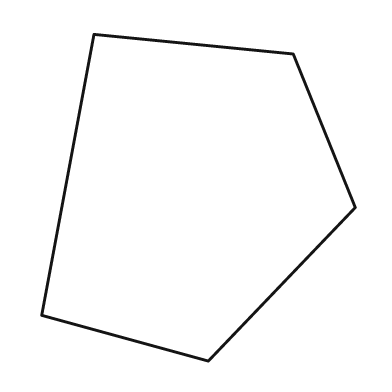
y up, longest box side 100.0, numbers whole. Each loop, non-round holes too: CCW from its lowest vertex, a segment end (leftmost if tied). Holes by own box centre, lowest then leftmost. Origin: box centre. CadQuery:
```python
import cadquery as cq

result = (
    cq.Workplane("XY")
    .moveTo(3.0, -50.0)
    .lineTo(48.0, -3.0)
    .lineTo(29.0, 44.0)
    .lineTo(-32.0, 50.0)
    .lineTo(-48.0, -36.0)
    .close()
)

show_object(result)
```